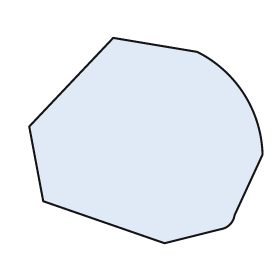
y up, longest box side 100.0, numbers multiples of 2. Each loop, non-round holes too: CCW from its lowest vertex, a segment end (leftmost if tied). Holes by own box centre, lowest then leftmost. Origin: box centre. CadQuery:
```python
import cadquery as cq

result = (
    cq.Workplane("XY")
    .moveTo(8.0, -44.0)
    .lineTo(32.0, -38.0)
    .threePointArc((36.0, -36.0), (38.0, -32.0))
    .lineTo(50.0, -6.0)
    .threePointArc((42.0, 20.0), (22.0, 38.0))
    .lineTo(-14.0, 44.0)
    .lineTo(-50.0, 6.0)
    .lineTo(-44.0, -26.0)
    .close()
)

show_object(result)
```